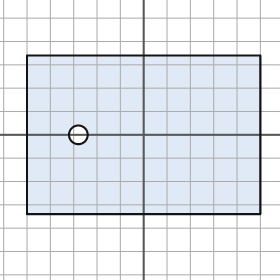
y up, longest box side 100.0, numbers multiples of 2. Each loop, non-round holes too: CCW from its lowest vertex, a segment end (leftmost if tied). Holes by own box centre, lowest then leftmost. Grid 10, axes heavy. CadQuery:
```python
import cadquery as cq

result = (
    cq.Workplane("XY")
    .moveTo(-50.0, -34.0)
    .lineTo(50.0, -34.0)
    .lineTo(50.0, 34.0)
    .lineTo(-50.0, 34.0)
    .close()
    .moveTo(-28.0, 0.0)
    .circle(4.0)
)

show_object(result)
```